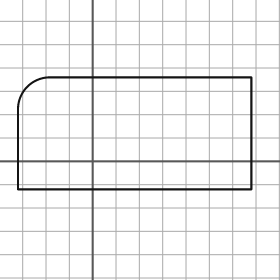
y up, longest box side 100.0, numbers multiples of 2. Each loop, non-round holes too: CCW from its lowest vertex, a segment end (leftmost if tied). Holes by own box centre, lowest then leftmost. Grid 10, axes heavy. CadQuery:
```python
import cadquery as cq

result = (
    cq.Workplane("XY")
    .moveTo(-32.0, -12.0)
    .lineTo(68.0, -12.0)
    .lineTo(68.0, 36.0)
    .lineTo(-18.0, 36.0)
    .threePointArc((-28.0, 32.0), (-32.0, 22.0))
    .close()
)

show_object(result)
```